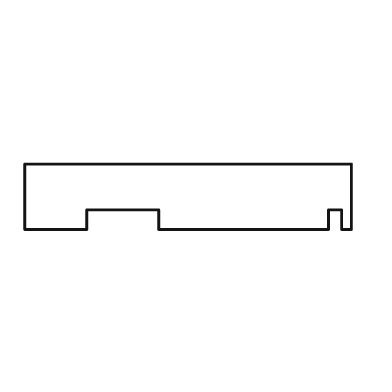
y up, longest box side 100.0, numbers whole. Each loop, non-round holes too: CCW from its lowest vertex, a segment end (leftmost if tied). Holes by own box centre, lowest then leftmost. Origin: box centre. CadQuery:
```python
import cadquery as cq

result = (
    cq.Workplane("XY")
    .moveTo(-50.0, -10.0)
    .lineTo(-31.0, -10.0)
    .lineTo(-31.0, -4.0)
    .lineTo(-9.0, -4.0)
    .lineTo(-9.0, -10.0)
    .lineTo(43.0, -10.0)
    .lineTo(43.0, -4.0)
    .lineTo(47.0, -4.0)
    .lineTo(47.0, -10.0)
    .lineTo(50.0, -10.0)
    .lineTo(50.0, 10.0)
    .lineTo(-50.0, 10.0)
    .close()
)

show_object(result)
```